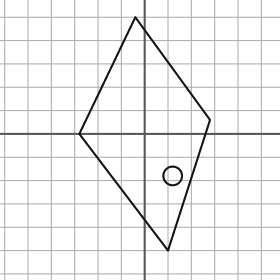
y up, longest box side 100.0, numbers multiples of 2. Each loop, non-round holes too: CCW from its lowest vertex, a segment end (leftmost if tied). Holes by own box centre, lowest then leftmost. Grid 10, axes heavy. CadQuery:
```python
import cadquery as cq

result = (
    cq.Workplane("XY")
    .moveTo(10.0, -50.0)
    .lineTo(28.0, 6.0)
    .lineTo(-4.0, 50.0)
    .lineTo(-28.0, 0.0)
    .close()
    .moveTo(12.0, -18.0)
    .circle(4.0)
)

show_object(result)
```